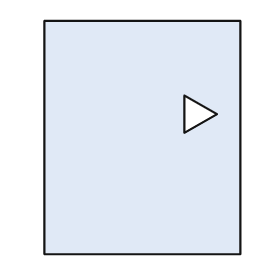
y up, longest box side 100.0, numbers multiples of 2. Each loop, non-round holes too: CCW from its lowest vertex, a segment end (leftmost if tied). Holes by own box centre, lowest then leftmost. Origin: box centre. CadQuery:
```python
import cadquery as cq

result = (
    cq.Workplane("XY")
    .moveTo(-42.0, -50.0)
    .lineTo(42.0, -50.0)
    .lineTo(42.0, 50.0)
    .lineTo(-42.0, 50.0)
    .close()
    .moveTo(18.0, 2.0)
    .lineTo(32.0, 10.0)
    .lineTo(18.0, 18.0)
    .close()
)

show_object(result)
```